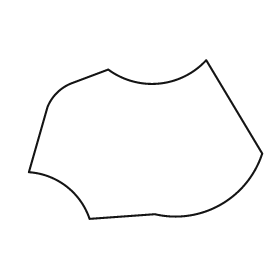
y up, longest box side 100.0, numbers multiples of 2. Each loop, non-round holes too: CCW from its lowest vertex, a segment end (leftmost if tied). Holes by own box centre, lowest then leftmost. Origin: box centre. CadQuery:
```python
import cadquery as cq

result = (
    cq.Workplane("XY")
    .moveTo(-24.0, -34.0)
    .lineTo(4.0, -32.0)
    .threePointArc((32.0, -28.0), (50.0, -6.0))
    .lineTo(26.0, 34.0)
    .threePointArc((6.0, 24.0), (-16.0, 30.0))
    .lineTo(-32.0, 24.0)
    .threePointArc((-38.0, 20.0), (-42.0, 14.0))
    .lineTo(-50.0, -14.0)
    .threePointArc((-34.0, -20.0), (-24.0, -34.0))
    .close()
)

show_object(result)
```